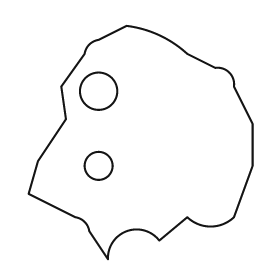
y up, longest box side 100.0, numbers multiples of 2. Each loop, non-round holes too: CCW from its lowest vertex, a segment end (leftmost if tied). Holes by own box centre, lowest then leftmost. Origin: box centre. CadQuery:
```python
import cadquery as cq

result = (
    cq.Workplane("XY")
    .moveTo(-14.0, -50.0)
    .threePointArc((-6.0, -38.0), (8.0, -42.0))
    .lineTo(20.0, -32.0)
    .threePointArc((30.0, -36.0), (40.0, -32.0))
    .lineTo(48.0, -10.0)
    .lineTo(48.0, 8.0)
    .lineTo(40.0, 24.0)
    .threePointArc((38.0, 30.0), (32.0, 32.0))
    .lineTo(20.0, 38.0)
    .threePointArc((8.0, 46.0), (-6.0, 50.0))
    .lineTo(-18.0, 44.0)
    .threePointArc((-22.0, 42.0), (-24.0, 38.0))
    .lineTo(-34.0, 24.0)
    .lineTo(-32.0, 10.0)
    .lineTo(-44.0, -8.0)
    .lineTo(-48.0, -22.0)
    .lineTo(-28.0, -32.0)
    .threePointArc((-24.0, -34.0), (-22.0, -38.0))
    .close()
    .moveTo(-18.0, -10.0)
    .circle(6.0)
    .moveTo(-18.0, 22.0)
    .circle(8.0)
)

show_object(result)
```